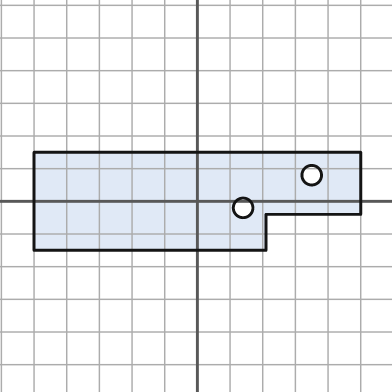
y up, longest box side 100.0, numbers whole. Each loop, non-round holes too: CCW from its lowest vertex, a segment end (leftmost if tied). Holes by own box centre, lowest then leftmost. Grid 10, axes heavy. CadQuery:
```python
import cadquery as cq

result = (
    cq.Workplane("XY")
    .moveTo(-50.0, -15.0)
    .lineTo(21.0, -15.0)
    .lineTo(21.0, -4.0)
    .lineTo(50.0, -4.0)
    .lineTo(50.0, 15.0)
    .lineTo(-50.0, 15.0)
    .close()
    .moveTo(14.0, -2.0)
    .circle(3.0)
    .moveTo(35.0, 8.0)
    .circle(3.0)
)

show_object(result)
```